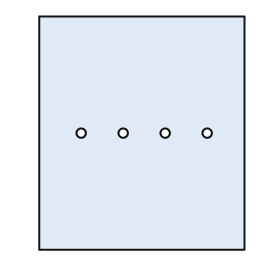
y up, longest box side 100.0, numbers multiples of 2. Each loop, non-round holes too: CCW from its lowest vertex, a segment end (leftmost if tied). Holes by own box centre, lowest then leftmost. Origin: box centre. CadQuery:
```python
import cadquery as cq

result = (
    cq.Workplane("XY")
    .moveTo(-44.0, -50.0)
    .lineTo(44.0, -50.0)
    .lineTo(44.0, 50.0)
    .lineTo(-44.0, 50.0)
    .close()
    .moveTo(-26.0, 0.0)
    .circle(2.0)
    .moveTo(-8.0, 0.0)
    .circle(2.0)
    .moveTo(10.0, 0.0)
    .circle(2.0)
    .moveTo(28.0, 0.0)
    .circle(2.0)
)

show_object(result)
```